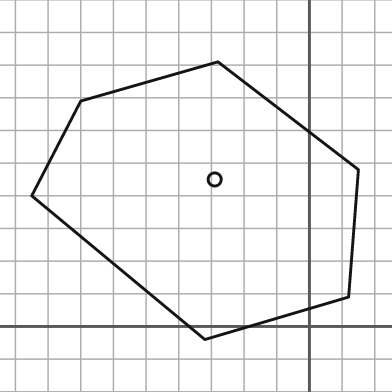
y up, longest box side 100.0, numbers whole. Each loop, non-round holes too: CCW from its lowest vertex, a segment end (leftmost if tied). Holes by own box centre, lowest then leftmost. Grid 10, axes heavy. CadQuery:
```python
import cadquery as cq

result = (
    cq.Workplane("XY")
    .moveTo(-32.0, -4.0)
    .lineTo(12.0, 9.0)
    .lineTo(15.0, 48.0)
    .lineTo(-28.0, 81.0)
    .lineTo(-70.0, 69.0)
    .lineTo(-85.0, 40.0)
    .close()
    .moveTo(-29.0, 45.0)
    .circle(2.0)
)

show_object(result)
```